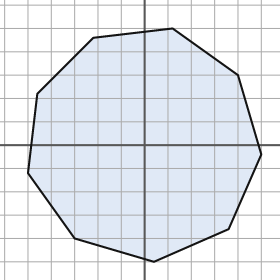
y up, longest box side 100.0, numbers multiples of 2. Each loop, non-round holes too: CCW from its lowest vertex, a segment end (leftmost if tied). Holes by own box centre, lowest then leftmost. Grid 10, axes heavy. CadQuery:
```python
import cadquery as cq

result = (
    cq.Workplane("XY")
    .moveTo(4.0, -50.0)
    .lineTo(36.0, -36.0)
    .lineTo(50.0, -4.0)
    .lineTo(40.0, 30.0)
    .lineTo(12.0, 50.0)
    .lineTo(-22.0, 46.0)
    .lineTo(-46.0, 22.0)
    .lineTo(-50.0, -12.0)
    .lineTo(-30.0, -40.0)
    .close()
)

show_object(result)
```